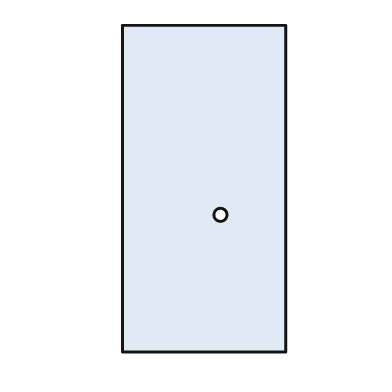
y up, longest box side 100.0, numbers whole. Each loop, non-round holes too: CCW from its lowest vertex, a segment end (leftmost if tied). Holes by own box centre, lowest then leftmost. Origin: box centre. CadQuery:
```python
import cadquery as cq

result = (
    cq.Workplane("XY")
    .moveTo(-25.0, -50.0)
    .lineTo(25.0, -50.0)
    .lineTo(25.0, 50.0)
    .lineTo(-25.0, 50.0)
    .close()
    .moveTo(5.0, -8.0)
    .circle(2.0)
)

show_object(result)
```